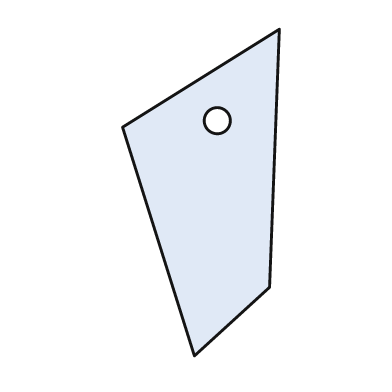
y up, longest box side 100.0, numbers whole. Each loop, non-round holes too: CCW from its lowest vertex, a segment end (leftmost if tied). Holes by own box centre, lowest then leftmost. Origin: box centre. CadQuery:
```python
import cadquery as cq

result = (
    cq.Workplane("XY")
    .moveTo(-2.0, -50.0)
    .lineTo(21.0, -29.0)
    .lineTo(24.0, 50.0)
    .lineTo(-24.0, 20.0)
    .close()
    .moveTo(5.0, 22.0)
    .circle(4.0)
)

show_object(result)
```